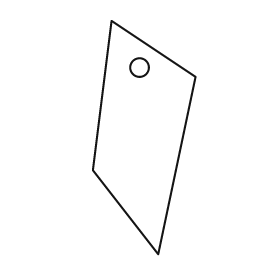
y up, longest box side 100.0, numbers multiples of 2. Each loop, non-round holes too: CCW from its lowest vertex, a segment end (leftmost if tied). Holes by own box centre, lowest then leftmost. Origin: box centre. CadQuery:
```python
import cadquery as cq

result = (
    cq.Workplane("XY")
    .moveTo(6.0, -50.0)
    .lineTo(22.0, 26.0)
    .lineTo(-14.0, 50.0)
    .lineTo(-22.0, -14.0)
    .close()
    .moveTo(-2.0, 30.0)
    .circle(4.0)
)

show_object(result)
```